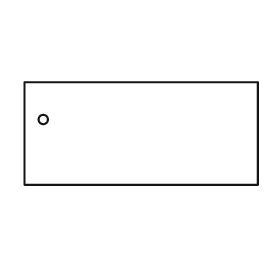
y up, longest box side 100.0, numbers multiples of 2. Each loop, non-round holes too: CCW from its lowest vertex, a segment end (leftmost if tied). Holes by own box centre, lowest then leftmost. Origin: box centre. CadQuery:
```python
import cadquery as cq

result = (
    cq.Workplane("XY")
    .moveTo(-50.0, -22.0)
    .lineTo(50.0, -22.0)
    .lineTo(50.0, 22.0)
    .lineTo(-50.0, 22.0)
    .close()
    .moveTo(-42.0, 6.0)
    .circle(2.0)
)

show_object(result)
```